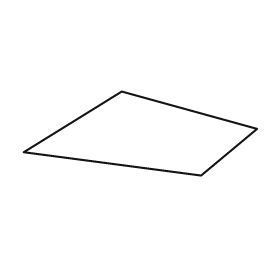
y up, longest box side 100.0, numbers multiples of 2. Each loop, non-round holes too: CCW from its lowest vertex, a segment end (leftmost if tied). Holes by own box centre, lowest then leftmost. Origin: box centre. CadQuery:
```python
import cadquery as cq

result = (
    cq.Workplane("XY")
    .moveTo(26.0, -18.0)
    .lineTo(50.0, 2.0)
    .lineTo(-8.0, 18.0)
    .lineTo(-50.0, -8.0)
    .close()
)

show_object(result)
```